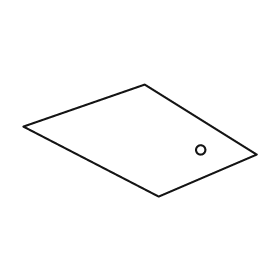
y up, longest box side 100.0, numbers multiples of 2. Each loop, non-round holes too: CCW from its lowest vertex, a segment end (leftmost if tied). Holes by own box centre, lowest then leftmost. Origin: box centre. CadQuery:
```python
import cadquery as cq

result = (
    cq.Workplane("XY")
    .moveTo(8.0, -24.0)
    .lineTo(50.0, -6.0)
    .lineTo(2.0, 24.0)
    .lineTo(-50.0, 6.0)
    .close()
    .moveTo(26.0, -4.0)
    .circle(2.0)
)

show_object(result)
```